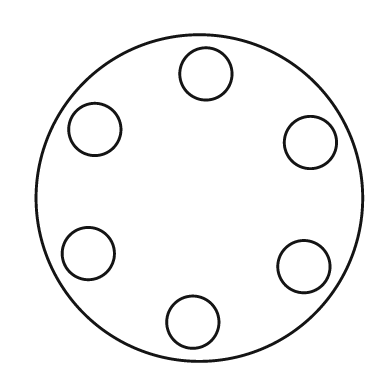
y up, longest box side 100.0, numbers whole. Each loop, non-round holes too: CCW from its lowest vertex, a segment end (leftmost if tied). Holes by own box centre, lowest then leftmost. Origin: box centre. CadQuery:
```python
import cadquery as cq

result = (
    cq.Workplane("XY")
    .moveTo(0.0, 0.0)
    .circle(50.0)
    .moveTo(-2.0, -38.0)
    .circle(8.0)
    .moveTo(32.0, -21.0)
    .circle(8.0)
    .moveTo(-34.0, -17.0)
    .circle(8.0)
    .moveTo(34.0, 17.0)
    .circle(8.0)
    .moveTo(-32.0, 21.0)
    .circle(8.0)
    .moveTo(2.0, 38.0)
    .circle(8.0)
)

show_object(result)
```